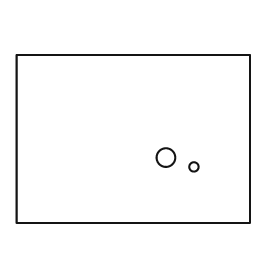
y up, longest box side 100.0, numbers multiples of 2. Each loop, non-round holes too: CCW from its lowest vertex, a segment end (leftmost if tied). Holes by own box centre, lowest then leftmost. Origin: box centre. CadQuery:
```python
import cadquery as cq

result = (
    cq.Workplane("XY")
    .moveTo(-50.0, -36.0)
    .lineTo(50.0, -36.0)
    .lineTo(50.0, 36.0)
    .lineTo(-50.0, 36.0)
    .close()
    .moveTo(26.0, -12.0)
    .circle(2.0)
    .moveTo(14.0, -8.0)
    .circle(4.0)
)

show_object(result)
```